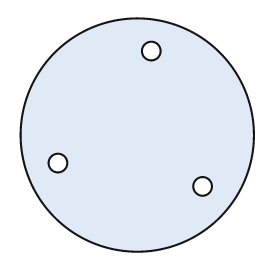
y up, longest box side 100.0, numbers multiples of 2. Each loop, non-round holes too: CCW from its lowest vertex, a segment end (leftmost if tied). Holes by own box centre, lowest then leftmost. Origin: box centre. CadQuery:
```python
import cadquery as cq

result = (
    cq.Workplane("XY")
    .moveTo(0.0, 0.0)
    .circle(50.0)
    .moveTo(28.0, -22.0)
    .circle(4.0)
    .moveTo(-34.0, -12.0)
    .circle(4.0)
    .moveTo(6.0, 36.0)
    .circle(4.0)
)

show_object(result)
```